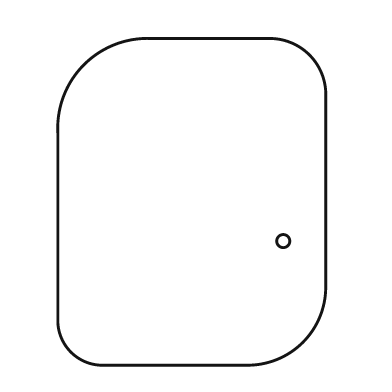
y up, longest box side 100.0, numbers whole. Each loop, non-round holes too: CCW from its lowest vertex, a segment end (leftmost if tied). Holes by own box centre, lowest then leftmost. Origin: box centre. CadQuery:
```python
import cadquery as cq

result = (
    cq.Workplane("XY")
    .moveTo(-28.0, -50.0)
    .lineTo(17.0, -50.0)
    .threePointArc((34.0, -43.0), (41.0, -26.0))
    .lineTo(41.0, 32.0)
    .threePointArc((36.0, 45.0), (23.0, 50.0))
    .lineTo(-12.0, 50.0)
    .threePointArc((-33.0, 42.0), (-41.0, 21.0))
    .lineTo(-41.0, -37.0)
    .threePointArc((-37.0, -46.0), (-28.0, -50.0))
    .close()
    .moveTo(28.0, -12.0)
    .circle(2.0)
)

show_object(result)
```